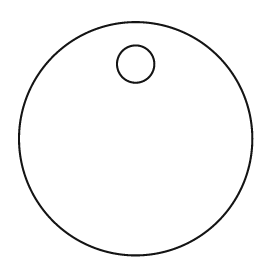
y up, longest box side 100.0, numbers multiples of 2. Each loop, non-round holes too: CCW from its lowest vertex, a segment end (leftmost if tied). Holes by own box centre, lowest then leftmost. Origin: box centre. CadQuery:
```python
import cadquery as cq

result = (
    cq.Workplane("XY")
    .moveTo(0.0, 0.0)
    .circle(50.0)
    .moveTo(0.0, 32.0)
    .circle(8.0)
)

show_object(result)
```